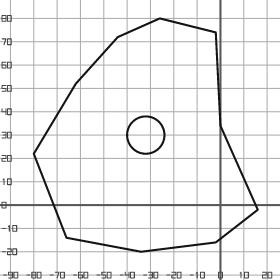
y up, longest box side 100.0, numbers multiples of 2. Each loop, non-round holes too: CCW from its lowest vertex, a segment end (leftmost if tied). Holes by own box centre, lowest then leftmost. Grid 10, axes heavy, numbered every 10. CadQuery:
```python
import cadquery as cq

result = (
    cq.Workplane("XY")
    .moveTo(-34.0, -20.0)
    .lineTo(-2.0, -16.0)
    .lineTo(16.0, -2.0)
    .lineTo(0.0, 34.0)
    .lineTo(-2.0, 74.0)
    .lineTo(-26.0, 80.0)
    .lineTo(-44.0, 72.0)
    .lineTo(-62.0, 52.0)
    .lineTo(-80.0, 22.0)
    .lineTo(-66.0, -14.0)
    .close()
    .moveTo(-32.0, 30.0)
    .circle(8.0)
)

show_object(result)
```